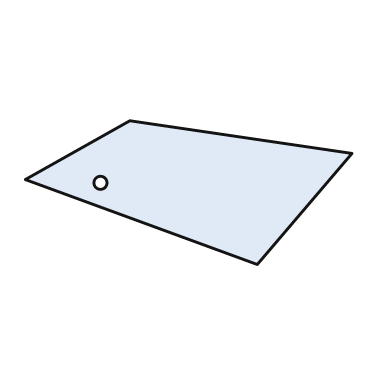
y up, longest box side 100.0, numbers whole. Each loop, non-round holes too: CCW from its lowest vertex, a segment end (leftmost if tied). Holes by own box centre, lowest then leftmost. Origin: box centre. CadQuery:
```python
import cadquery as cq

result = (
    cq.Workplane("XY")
    .moveTo(21.0, -22.0)
    .lineTo(50.0, 12.0)
    .lineTo(-18.0, 22.0)
    .lineTo(-50.0, 4.0)
    .close()
    .moveTo(-27.0, 3.0)
    .circle(2.0)
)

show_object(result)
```